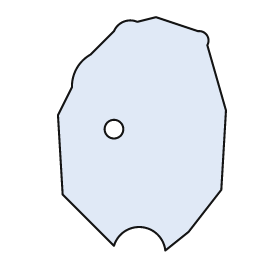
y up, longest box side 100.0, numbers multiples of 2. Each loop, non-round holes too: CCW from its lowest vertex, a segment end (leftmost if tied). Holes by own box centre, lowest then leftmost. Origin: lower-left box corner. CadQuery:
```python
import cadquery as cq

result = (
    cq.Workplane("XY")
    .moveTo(46.0, 0.0)
    .lineTo(56.0, 8.0)
    .lineTo(70.0, 26.0)
    .lineTo(72.0, 60.0)
    .lineTo(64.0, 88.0)
    .threePointArc((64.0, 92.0), (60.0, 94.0))
    .lineTo(42.0, 100.0)
    .lineTo(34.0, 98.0)
    .threePointArc((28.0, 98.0), (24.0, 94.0))
    .lineTo(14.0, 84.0)
    .threePointArc((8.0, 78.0), (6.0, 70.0))
    .lineTo(0.0, 58.0)
    .lineTo(2.0, 24.0)
    .lineTo(24.0, 2.0)
    .threePointArc((36.0, 10.0), (46.0, 0.0))
    .close()
    .moveTo(24.0, 52.0)
    .circle(4.0)
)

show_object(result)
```